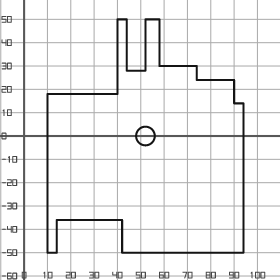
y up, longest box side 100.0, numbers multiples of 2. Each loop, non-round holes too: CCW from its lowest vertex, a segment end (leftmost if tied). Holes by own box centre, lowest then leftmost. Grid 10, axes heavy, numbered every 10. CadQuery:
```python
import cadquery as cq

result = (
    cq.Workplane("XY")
    .moveTo(10.0, -50.0)
    .lineTo(14.0, -50.0)
    .lineTo(14.0, -36.0)
    .lineTo(42.0, -36.0)
    .lineTo(42.0, -50.0)
    .lineTo(94.0, -50.0)
    .lineTo(94.0, 14.0)
    .lineTo(90.0, 14.0)
    .lineTo(90.0, 24.0)
    .lineTo(74.0, 24.0)
    .lineTo(74.0, 30.0)
    .lineTo(58.0, 30.0)
    .lineTo(58.0, 50.0)
    .lineTo(52.0, 50.0)
    .lineTo(52.0, 28.0)
    .lineTo(44.0, 28.0)
    .lineTo(44.0, 50.0)
    .lineTo(40.0, 50.0)
    .lineTo(40.0, 18.0)
    .lineTo(10.0, 18.0)
    .close()
    .moveTo(52.0, 0.0)
    .circle(4.0)
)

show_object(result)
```